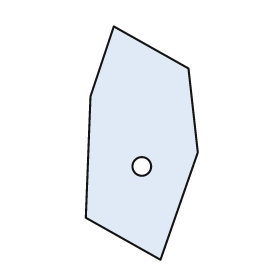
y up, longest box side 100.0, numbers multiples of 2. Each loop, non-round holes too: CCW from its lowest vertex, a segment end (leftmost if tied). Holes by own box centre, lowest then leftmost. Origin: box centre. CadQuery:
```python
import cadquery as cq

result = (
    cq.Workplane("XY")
    .moveTo(8.0, -50.0)
    .lineTo(24.0, -4.0)
    .lineTo(20.0, 32.0)
    .lineTo(-12.0, 50.0)
    .lineTo(-22.0, 20.0)
    .lineTo(-24.0, -32.0)
    .close()
    .moveTo(0.0, -10.0)
    .circle(4.0)
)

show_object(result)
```